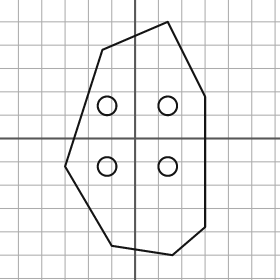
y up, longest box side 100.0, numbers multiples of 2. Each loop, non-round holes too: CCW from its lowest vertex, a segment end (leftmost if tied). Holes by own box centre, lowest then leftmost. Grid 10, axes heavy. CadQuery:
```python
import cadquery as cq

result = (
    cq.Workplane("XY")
    .moveTo(16.0, -50.0)
    .lineTo(30.0, -38.0)
    .lineTo(30.0, 18.0)
    .lineTo(14.0, 50.0)
    .lineTo(-14.0, 38.0)
    .lineTo(-30.0, -12.0)
    .lineTo(-10.0, -46.0)
    .close()
    .moveTo(-12.0, -12.0)
    .circle(4.0)
    .moveTo(14.0, -12.0)
    .circle(4.0)
    .moveTo(-12.0, 14.0)
    .circle(4.0)
    .moveTo(14.0, 14.0)
    .circle(4.0)
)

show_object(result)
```